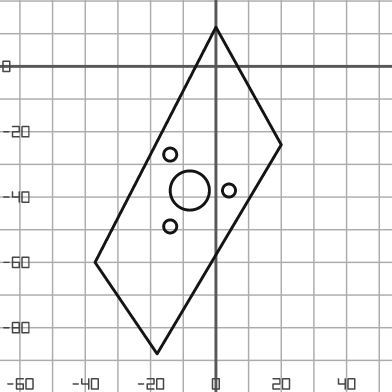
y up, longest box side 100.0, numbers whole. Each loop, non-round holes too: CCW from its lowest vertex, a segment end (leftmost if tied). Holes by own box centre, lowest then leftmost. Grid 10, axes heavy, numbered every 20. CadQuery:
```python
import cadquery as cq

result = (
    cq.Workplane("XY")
    .moveTo(-18.0, -88.0)
    .lineTo(20.0, -24.0)
    .lineTo(0.0, 12.0)
    .lineTo(-37.0, -60.0)
    .close()
    .moveTo(-14.0, -49.0)
    .circle(2.0)
    .moveTo(-8.0, -38.0)
    .circle(6.0)
    .moveTo(4.0, -38.0)
    .circle(2.0)
    .moveTo(-14.0, -27.0)
    .circle(2.0)
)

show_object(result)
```